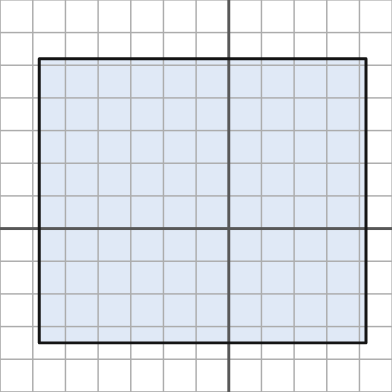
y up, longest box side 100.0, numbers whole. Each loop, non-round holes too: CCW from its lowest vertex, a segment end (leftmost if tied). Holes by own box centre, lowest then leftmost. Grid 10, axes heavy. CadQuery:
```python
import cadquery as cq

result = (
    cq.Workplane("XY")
    .moveTo(-58.0, -35.0)
    .lineTo(42.0, -35.0)
    .lineTo(42.0, 52.0)
    .lineTo(-58.0, 52.0)
    .close()
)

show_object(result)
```